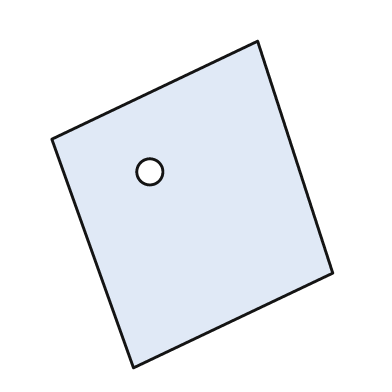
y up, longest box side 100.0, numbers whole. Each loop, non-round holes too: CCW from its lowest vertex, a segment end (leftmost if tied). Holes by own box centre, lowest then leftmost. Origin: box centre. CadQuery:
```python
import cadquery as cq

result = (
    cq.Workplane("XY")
    .moveTo(-18.0, -50.0)
    .lineTo(43.0, -21.0)
    .lineTo(20.0, 50.0)
    .lineTo(-43.0, 20.0)
    .close()
    .moveTo(-13.0, 10.0)
    .circle(4.0)
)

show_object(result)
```